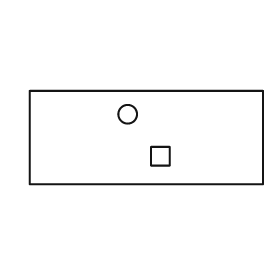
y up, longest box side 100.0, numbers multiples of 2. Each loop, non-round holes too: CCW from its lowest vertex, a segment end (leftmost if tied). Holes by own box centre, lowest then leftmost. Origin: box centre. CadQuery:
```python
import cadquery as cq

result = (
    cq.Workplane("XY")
    .moveTo(-50.0, -20.0)
    .lineTo(50.0, -20.0)
    .lineTo(50.0, 20.0)
    .lineTo(-50.0, 20.0)
    .close()
    .moveTo(2.0, -12.0)
    .lineTo(10.0, -12.0)
    .lineTo(10.0, -4.0)
    .lineTo(2.0, -4.0)
    .close()
    .moveTo(-8.0, 10.0)
    .circle(4.0)
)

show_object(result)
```